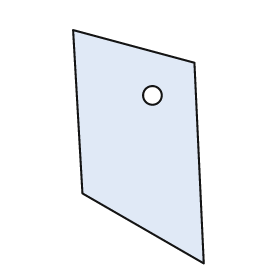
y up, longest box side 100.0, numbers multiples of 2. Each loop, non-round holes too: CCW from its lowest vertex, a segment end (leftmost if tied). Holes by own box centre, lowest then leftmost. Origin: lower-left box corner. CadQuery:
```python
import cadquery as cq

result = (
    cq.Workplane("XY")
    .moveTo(56.0, 0.0)
    .lineTo(52.0, 86.0)
    .lineTo(0.0, 100.0)
    .lineTo(4.0, 30.0)
    .close()
    .moveTo(34.0, 72.0)
    .circle(4.0)
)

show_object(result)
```